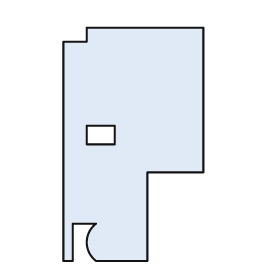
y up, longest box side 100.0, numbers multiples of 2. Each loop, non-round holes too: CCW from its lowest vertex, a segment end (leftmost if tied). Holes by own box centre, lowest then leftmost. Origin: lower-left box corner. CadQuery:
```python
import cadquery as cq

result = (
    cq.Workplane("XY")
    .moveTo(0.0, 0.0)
    .lineTo(4.0, 0.0)
    .lineTo(4.0, 16.0)
    .lineTo(14.0, 16.0)
    .threePointArc((10.0, 8.0), (14.0, 0.0))
    .lineTo(36.0, 0.0)
    .lineTo(36.0, 38.0)
    .lineTo(60.0, 38.0)
    .lineTo(60.0, 100.0)
    .lineTo(10.0, 100.0)
    .lineTo(10.0, 94.0)
    .lineTo(0.0, 94.0)
    .close()
    .moveTo(10.0, 50.0)
    .lineTo(22.0, 50.0)
    .lineTo(22.0, 58.0)
    .lineTo(10.0, 58.0)
    .close()
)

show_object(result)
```